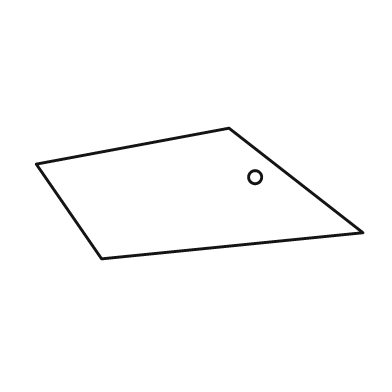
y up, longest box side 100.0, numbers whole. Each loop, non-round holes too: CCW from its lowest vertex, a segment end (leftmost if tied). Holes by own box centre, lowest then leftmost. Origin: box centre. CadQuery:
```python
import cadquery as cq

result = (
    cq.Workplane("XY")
    .moveTo(-30.0, -20.0)
    .lineTo(50.0, -12.0)
    .lineTo(9.0, 20.0)
    .lineTo(-50.0, 9.0)
    .close()
    .moveTo(17.0, 5.0)
    .circle(2.0)
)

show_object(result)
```